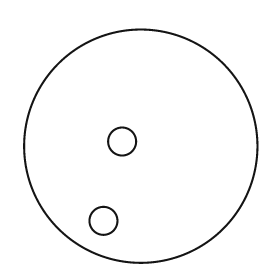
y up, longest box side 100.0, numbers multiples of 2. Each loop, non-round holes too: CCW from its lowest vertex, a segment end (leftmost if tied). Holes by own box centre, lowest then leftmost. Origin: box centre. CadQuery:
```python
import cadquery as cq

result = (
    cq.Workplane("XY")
    .moveTo(0.0, 0.0)
    .circle(50.0)
    .moveTo(-16.0, -32.0)
    .circle(6.0)
    .moveTo(-8.0, 2.0)
    .circle(6.0)
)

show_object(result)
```